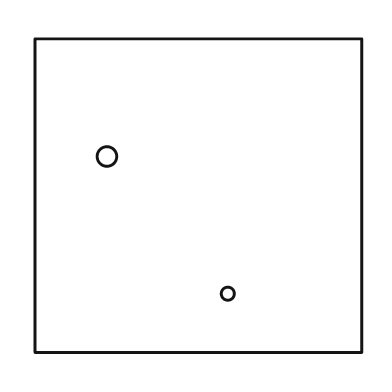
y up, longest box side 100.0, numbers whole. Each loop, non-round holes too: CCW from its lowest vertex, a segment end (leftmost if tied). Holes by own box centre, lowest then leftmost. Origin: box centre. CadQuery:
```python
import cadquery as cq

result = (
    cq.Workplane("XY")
    .moveTo(-50.0, -48.0)
    .lineTo(50.0, -48.0)
    .lineTo(50.0, 48.0)
    .lineTo(-50.0, 48.0)
    .close()
    .moveTo(9.0, -30.0)
    .circle(2.0)
    .moveTo(-28.0, 12.0)
    .circle(3.0)
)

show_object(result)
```